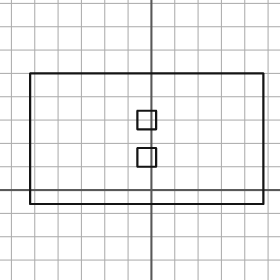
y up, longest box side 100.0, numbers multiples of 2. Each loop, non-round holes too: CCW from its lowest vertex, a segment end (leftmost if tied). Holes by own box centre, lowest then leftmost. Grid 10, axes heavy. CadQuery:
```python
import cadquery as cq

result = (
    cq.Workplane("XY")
    .moveTo(-52.0, -6.0)
    .lineTo(48.0, -6.0)
    .lineTo(48.0, 50.0)
    .lineTo(-52.0, 50.0)
    .close()
    .moveTo(-6.0, 10.0)
    .lineTo(2.0, 10.0)
    .lineTo(2.0, 18.0)
    .lineTo(-6.0, 18.0)
    .close()
    .moveTo(-6.0, 26.0)
    .lineTo(2.0, 26.0)
    .lineTo(2.0, 34.0)
    .lineTo(-6.0, 34.0)
    .close()
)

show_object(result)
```